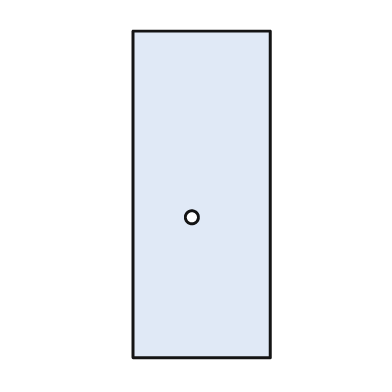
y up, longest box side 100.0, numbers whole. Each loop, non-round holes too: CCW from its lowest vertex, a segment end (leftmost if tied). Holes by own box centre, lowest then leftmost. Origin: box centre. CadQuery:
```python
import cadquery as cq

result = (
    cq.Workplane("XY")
    .moveTo(-21.0, -50.0)
    .lineTo(21.0, -50.0)
    .lineTo(21.0, 50.0)
    .lineTo(-21.0, 50.0)
    .close()
    .moveTo(-3.0, -7.0)
    .circle(2.0)
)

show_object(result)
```